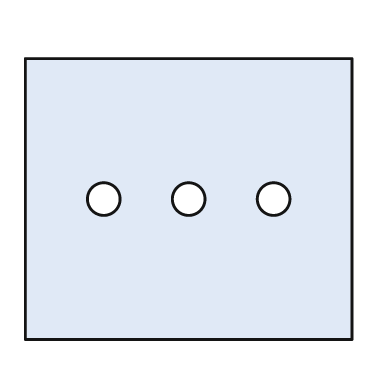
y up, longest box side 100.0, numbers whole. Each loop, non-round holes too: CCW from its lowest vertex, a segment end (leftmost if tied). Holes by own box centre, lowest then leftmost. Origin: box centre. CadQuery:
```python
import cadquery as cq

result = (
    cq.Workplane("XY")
    .moveTo(-50.0, -43.0)
    .lineTo(50.0, -43.0)
    .lineTo(50.0, 43.0)
    .lineTo(-50.0, 43.0)
    .close()
    .moveTo(-26.0, 0.0)
    .circle(5.0)
    .moveTo(0.0, 0.0)
    .circle(5.0)
    .moveTo(26.0, 0.0)
    .circle(5.0)
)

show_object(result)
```